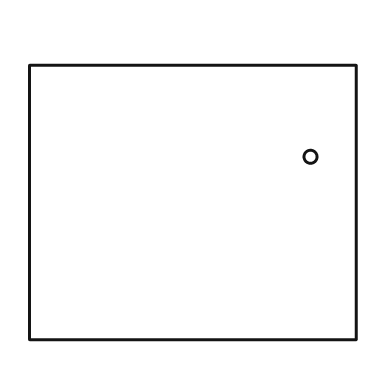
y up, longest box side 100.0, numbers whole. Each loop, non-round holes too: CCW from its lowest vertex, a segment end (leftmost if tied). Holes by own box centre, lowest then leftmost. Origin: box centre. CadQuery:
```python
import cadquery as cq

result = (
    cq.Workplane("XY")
    .moveTo(-50.0, -42.0)
    .lineTo(50.0, -42.0)
    .lineTo(50.0, 42.0)
    .lineTo(-50.0, 42.0)
    .close()
    .moveTo(36.0, 14.0)
    .circle(2.0)
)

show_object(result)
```